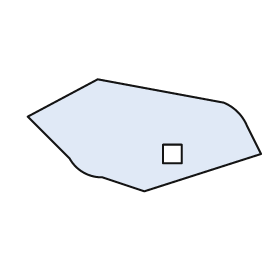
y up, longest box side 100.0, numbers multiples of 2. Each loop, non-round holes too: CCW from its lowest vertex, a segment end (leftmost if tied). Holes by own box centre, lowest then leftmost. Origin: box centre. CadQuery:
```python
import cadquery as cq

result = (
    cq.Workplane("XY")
    .moveTo(0.0, -24.0)
    .lineTo(50.0, -8.0)
    .lineTo(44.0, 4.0)
    .threePointArc((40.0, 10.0), (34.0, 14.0))
    .lineTo(-20.0, 24.0)
    .lineTo(-50.0, 8.0)
    .lineTo(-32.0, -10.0)
    .threePointArc((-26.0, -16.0), (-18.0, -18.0))
    .close()
    .moveTo(8.0, -12.0)
    .lineTo(16.0, -12.0)
    .lineTo(16.0, -4.0)
    .lineTo(8.0, -4.0)
    .close()
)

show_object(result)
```